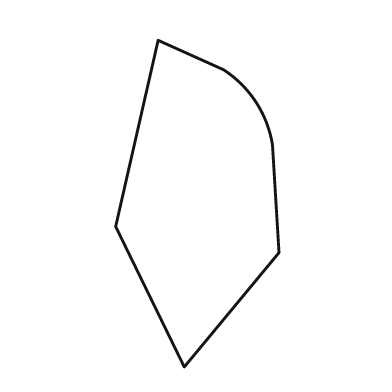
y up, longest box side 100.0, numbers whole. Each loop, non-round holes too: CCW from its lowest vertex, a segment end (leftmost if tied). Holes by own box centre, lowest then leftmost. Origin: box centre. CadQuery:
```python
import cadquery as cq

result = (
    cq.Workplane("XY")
    .moveTo(-4.0, -50.0)
    .lineTo(25.0, -15.0)
    .lineTo(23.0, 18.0)
    .threePointArc((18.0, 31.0), (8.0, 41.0))
    .lineTo(-12.0, 50.0)
    .lineTo(-25.0, -7.0)
    .close()
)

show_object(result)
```